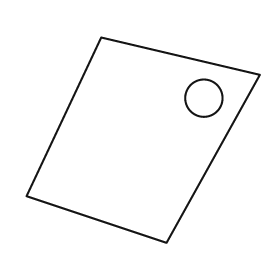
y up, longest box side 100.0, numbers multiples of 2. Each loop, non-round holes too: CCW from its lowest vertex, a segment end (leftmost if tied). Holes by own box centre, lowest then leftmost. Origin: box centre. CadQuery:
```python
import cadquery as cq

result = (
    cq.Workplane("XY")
    .moveTo(10.0, -44.0)
    .lineTo(50.0, 28.0)
    .lineTo(-18.0, 44.0)
    .lineTo(-50.0, -24.0)
    .close()
    .moveTo(26.0, 18.0)
    .circle(8.0)
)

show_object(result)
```